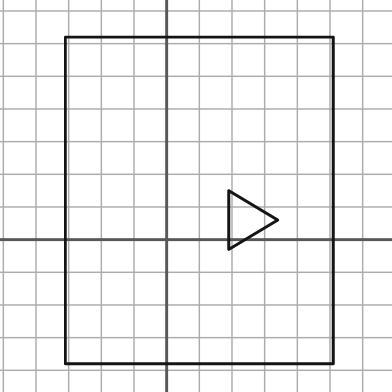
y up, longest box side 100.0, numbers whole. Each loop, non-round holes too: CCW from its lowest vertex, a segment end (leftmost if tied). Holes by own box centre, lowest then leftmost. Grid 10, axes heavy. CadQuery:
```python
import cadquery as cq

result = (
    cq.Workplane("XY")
    .moveTo(-31.0, -38.0)
    .lineTo(51.0, -38.0)
    .lineTo(51.0, 62.0)
    .lineTo(-31.0, 62.0)
    .close()
    .moveTo(19.0, -3.0)
    .lineTo(34.0, 6.0)
    .lineTo(19.0, 15.0)
    .close()
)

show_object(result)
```